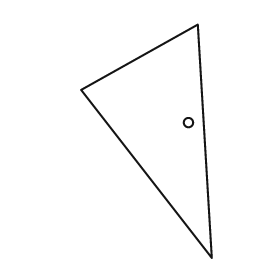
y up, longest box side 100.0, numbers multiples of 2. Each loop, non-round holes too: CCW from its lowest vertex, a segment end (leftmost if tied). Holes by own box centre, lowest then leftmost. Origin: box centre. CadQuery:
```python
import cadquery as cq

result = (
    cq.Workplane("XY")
    .moveTo(28.0, -50.0)
    .lineTo(22.0, 50.0)
    .lineTo(-28.0, 22.0)
    .close()
    .moveTo(18.0, 8.0)
    .circle(2.0)
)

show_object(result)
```